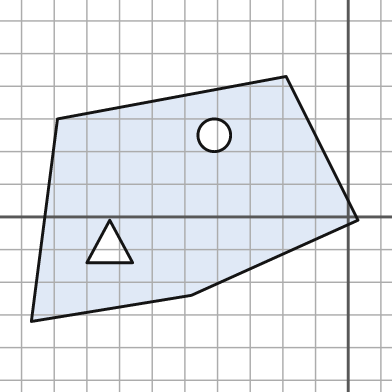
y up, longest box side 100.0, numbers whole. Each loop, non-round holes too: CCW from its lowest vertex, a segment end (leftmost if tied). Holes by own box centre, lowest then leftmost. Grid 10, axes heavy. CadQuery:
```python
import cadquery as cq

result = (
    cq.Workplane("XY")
    .moveTo(-97.0, -32.0)
    .lineTo(-48.0, -24.0)
    .lineTo(3.0, -1.0)
    .lineTo(-19.0, 43.0)
    .lineTo(-89.0, 30.0)
    .close()
    .moveTo(-80.0, -14.0)
    .lineTo(-66.0, -14.0)
    .lineTo(-73.0, -1.0)
    .close()
    .moveTo(-41.0, 25.0)
    .circle(5.0)
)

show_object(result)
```